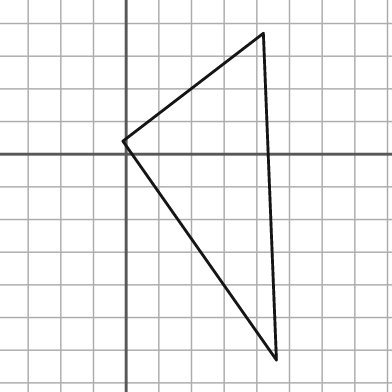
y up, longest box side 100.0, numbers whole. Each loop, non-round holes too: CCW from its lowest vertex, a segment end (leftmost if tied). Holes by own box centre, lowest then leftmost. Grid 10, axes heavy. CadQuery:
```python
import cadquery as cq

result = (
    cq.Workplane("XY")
    .moveTo(46.0, -63.0)
    .lineTo(42.0, 37.0)
    .lineTo(-1.0, 4.0)
    .close()
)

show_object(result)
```